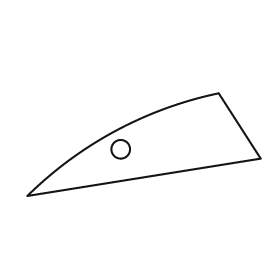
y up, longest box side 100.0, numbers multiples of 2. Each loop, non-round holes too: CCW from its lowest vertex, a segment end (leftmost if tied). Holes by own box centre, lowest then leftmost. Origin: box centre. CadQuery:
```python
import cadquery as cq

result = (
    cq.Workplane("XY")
    .moveTo(-50.0, -22.0)
    .lineTo(50.0, -6.0)
    .lineTo(32.0, 22.0)
    .threePointArc((-12.0, 6.0), (-50.0, -22.0))
    .close()
    .moveTo(-10.0, -2.0)
    .circle(4.0)
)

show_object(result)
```